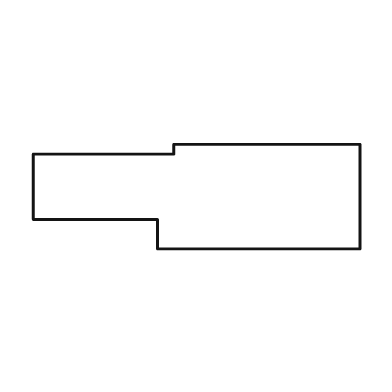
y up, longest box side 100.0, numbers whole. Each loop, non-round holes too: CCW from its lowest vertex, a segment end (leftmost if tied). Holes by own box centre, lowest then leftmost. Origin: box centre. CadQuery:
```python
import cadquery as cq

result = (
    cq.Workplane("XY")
    .moveTo(-12.0, -16.0)
    .lineTo(50.0, -16.0)
    .lineTo(50.0, 16.0)
    .lineTo(-7.0, 16.0)
    .lineTo(-7.0, 13.0)
    .lineTo(-50.0, 13.0)
    .lineTo(-50.0, -7.0)
    .lineTo(-12.0, -7.0)
    .close()
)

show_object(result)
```